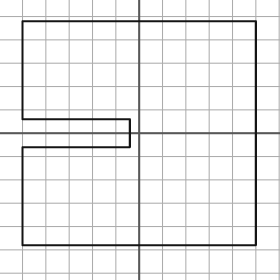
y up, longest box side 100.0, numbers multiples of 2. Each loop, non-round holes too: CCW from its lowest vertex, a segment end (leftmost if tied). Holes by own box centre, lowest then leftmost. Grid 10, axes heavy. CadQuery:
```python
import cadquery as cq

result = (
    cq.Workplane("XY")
    .moveTo(-50.0, -48.0)
    .lineTo(50.0, -48.0)
    .lineTo(50.0, 48.0)
    .lineTo(-50.0, 48.0)
    .lineTo(-50.0, 6.0)
    .lineTo(-4.0, 6.0)
    .lineTo(-4.0, -6.0)
    .lineTo(-50.0, -6.0)
    .close()
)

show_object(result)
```